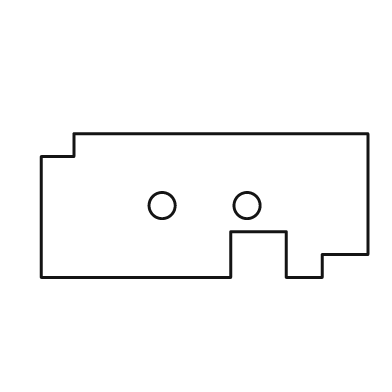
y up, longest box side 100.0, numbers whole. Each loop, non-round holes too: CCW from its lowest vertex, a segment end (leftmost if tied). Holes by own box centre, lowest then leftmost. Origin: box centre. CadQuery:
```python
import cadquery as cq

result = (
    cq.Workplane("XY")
    .moveTo(-50.0, -22.0)
    .lineTo(8.0, -22.0)
    .lineTo(8.0, -8.0)
    .lineTo(25.0, -8.0)
    .lineTo(25.0, -22.0)
    .lineTo(36.0, -22.0)
    .lineTo(36.0, -15.0)
    .lineTo(50.0, -15.0)
    .lineTo(50.0, 22.0)
    .lineTo(-40.0, 22.0)
    .lineTo(-40.0, 15.0)
    .lineTo(-50.0, 15.0)
    .close()
    .moveTo(-13.0, 0.0)
    .circle(4.0)
    .moveTo(13.0, 0.0)
    .circle(4.0)
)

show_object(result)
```